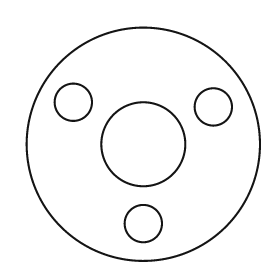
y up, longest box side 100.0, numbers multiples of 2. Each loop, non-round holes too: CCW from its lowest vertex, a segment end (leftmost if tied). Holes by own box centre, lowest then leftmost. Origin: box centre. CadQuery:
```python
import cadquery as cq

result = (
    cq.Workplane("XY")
    .moveTo(0.0, 0.0)
    .circle(50.0)
    .moveTo(0.0, -34.0)
    .circle(8.0)
    .moveTo(0.0, 0.0)
    .circle(18.0)
    .moveTo(30.0, 16.0)
    .circle(8.0)
    .moveTo(-30.0, 18.0)
    .circle(8.0)
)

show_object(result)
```